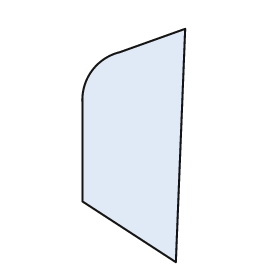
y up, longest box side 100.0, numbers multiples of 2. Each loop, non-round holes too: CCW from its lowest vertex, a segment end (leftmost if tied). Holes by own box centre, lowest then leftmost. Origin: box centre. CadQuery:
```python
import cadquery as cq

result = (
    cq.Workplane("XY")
    .moveTo(18.0, -50.0)
    .lineTo(22.0, 50.0)
    .lineTo(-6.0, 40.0)
    .threePointArc((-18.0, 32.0), (-22.0, 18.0))
    .lineTo(-22.0, -24.0)
    .close()
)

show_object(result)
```